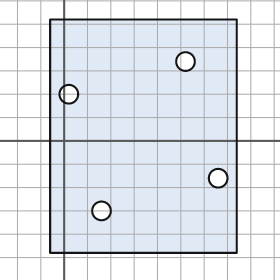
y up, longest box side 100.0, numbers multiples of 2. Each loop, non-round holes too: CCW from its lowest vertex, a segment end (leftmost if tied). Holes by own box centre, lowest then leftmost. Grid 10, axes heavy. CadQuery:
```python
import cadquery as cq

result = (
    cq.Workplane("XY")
    .moveTo(-6.0, -48.0)
    .lineTo(74.0, -48.0)
    .lineTo(74.0, 52.0)
    .lineTo(-6.0, 52.0)
    .close()
    .moveTo(16.0, -30.0)
    .circle(4.0)
    .moveTo(66.0, -16.0)
    .circle(4.0)
    .moveTo(2.0, 20.0)
    .circle(4.0)
    .moveTo(52.0, 34.0)
    .circle(4.0)
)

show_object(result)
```